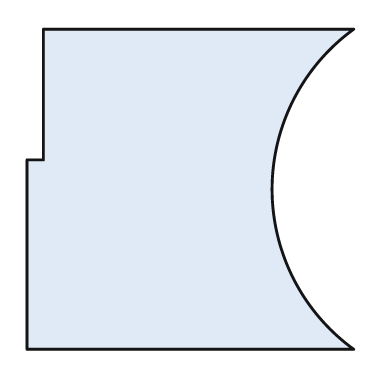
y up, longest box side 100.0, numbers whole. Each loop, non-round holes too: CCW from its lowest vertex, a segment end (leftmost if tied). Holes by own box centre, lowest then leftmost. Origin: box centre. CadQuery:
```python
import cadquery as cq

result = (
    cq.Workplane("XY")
    .moveTo(-50.0, -49.0)
    .lineTo(50.0, -49.0)
    .threePointArc((25.0, 0.0), (50.0, 49.0))
    .lineTo(-45.0, 49.0)
    .lineTo(-45.0, 9.0)
    .lineTo(-50.0, 9.0)
    .close()
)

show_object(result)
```